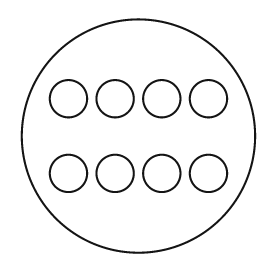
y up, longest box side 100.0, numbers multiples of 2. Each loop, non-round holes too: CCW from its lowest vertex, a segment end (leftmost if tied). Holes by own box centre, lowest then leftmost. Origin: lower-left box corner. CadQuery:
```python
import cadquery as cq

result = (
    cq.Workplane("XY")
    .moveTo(50.0, 50.0)
    .circle(50.0)
    .moveTo(20.0, 34.0)
    .circle(8.0)
    .moveTo(40.0, 34.0)
    .circle(8.0)
    .moveTo(60.0, 34.0)
    .circle(8.0)
    .moveTo(80.0, 34.0)
    .circle(8.0)
    .moveTo(20.0, 66.0)
    .circle(8.0)
    .moveTo(40.0, 66.0)
    .circle(8.0)
    .moveTo(60.0, 66.0)
    .circle(8.0)
    .moveTo(80.0, 66.0)
    .circle(8.0)
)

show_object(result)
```